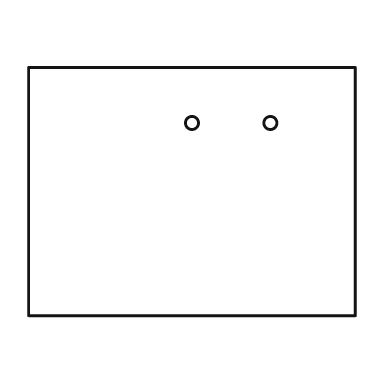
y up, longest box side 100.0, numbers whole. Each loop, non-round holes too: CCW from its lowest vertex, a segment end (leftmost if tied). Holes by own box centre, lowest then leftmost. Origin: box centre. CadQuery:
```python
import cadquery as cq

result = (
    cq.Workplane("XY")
    .moveTo(-50.0, -38.0)
    .lineTo(50.0, -38.0)
    .lineTo(50.0, 38.0)
    .lineTo(-50.0, 38.0)
    .close()
    .moveTo(0.0, 21.0)
    .circle(2.0)
    .moveTo(24.0, 21.0)
    .circle(2.0)
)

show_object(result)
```